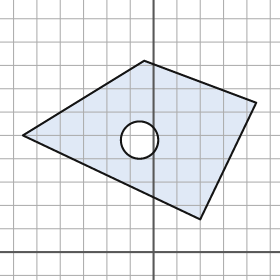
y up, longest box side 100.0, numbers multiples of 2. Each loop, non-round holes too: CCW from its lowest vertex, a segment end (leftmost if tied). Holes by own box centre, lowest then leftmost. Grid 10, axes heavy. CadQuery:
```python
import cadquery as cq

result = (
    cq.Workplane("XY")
    .moveTo(20.0, 14.0)
    .lineTo(44.0, 64.0)
    .lineTo(-4.0, 82.0)
    .lineTo(-56.0, 50.0)
    .close()
    .moveTo(-6.0, 48.0)
    .circle(8.0)
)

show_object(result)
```